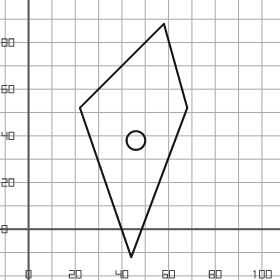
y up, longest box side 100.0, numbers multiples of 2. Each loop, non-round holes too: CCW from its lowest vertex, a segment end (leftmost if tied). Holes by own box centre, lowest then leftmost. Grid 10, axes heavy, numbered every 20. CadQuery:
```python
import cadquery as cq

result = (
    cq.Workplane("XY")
    .moveTo(44.0, -12.0)
    .lineTo(68.0, 52.0)
    .lineTo(58.0, 88.0)
    .lineTo(22.0, 52.0)
    .close()
    .moveTo(46.0, 38.0)
    .circle(4.0)
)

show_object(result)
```